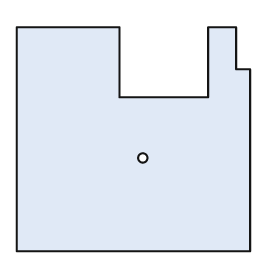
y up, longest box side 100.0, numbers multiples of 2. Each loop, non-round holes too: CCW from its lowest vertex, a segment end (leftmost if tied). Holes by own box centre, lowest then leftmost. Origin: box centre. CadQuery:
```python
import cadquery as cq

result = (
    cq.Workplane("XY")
    .moveTo(-50.0, -48.0)
    .lineTo(50.0, -48.0)
    .lineTo(50.0, 30.0)
    .lineTo(44.0, 30.0)
    .lineTo(44.0, 48.0)
    .lineTo(32.0, 48.0)
    .lineTo(32.0, 18.0)
    .lineTo(-6.0, 18.0)
    .lineTo(-6.0, 48.0)
    .lineTo(-50.0, 48.0)
    .close()
    .moveTo(4.0, -8.0)
    .circle(2.0)
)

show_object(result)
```